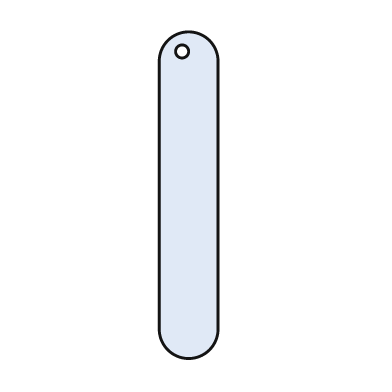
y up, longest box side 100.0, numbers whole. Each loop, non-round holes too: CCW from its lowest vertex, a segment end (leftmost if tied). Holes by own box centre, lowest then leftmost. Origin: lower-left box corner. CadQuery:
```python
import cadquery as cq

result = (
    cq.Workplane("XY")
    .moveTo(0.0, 9.0)
    .threePointArc((9.0, 0.0), (18.0, 9.0))
    .lineTo(18.0, 91.0)
    .threePointArc((9.0, 100.0), (0.0, 91.0))
    .close()
    .moveTo(7.0, 94.0)
    .circle(2.0)
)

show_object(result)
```